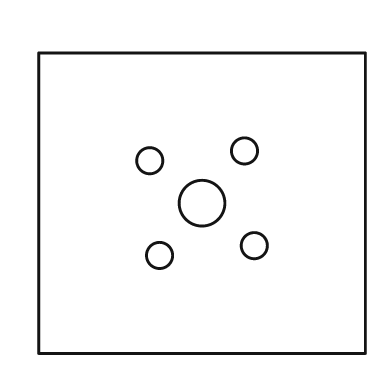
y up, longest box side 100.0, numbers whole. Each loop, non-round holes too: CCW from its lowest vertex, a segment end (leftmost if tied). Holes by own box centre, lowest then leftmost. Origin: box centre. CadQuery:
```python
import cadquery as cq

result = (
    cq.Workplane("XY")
    .moveTo(-50.0, -46.0)
    .lineTo(50.0, -46.0)
    .lineTo(50.0, 46.0)
    .lineTo(-50.0, 46.0)
    .close()
    .moveTo(-13.0, -16.0)
    .circle(4.0)
    .moveTo(16.0, -13.0)
    .circle(4.0)
    .moveTo(0.0, 0.0)
    .circle(7.0)
    .moveTo(-16.0, 13.0)
    .circle(4.0)
    .moveTo(13.0, 16.0)
    .circle(4.0)
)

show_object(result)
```